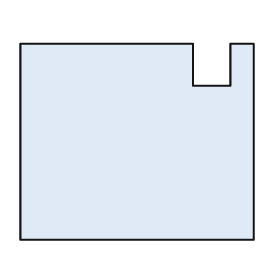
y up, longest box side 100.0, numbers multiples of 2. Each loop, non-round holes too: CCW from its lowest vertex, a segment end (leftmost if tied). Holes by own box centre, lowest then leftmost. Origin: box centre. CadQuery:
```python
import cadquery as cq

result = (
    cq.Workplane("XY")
    .moveTo(-50.0, -42.0)
    .lineTo(50.0, -42.0)
    .lineTo(50.0, 42.0)
    .lineTo(40.0, 42.0)
    .lineTo(40.0, 24.0)
    .lineTo(24.0, 24.0)
    .lineTo(24.0, 42.0)
    .lineTo(-50.0, 42.0)
    .close()
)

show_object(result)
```